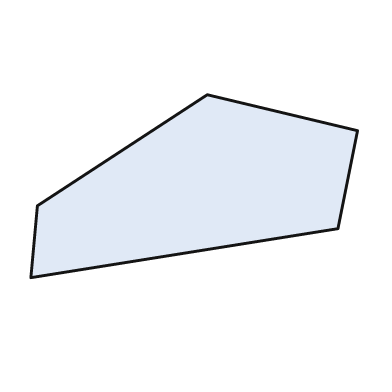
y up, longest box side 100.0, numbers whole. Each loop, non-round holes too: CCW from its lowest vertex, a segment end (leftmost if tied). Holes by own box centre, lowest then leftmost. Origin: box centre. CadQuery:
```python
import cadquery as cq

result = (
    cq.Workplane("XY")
    .moveTo(-50.0, -28.0)
    .lineTo(44.0, -13.0)
    .lineTo(50.0, 17.0)
    .lineTo(4.0, 28.0)
    .lineTo(-48.0, -6.0)
    .close()
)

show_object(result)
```